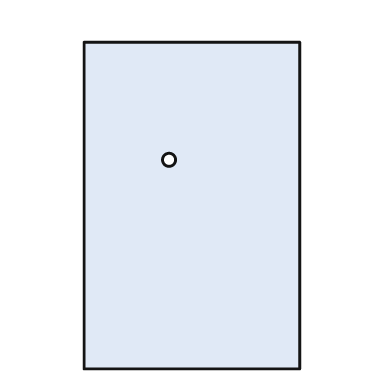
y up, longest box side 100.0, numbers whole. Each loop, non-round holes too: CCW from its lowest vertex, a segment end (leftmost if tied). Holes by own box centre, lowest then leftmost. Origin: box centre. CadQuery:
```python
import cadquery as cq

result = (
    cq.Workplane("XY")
    .moveTo(-33.0, -50.0)
    .lineTo(33.0, -50.0)
    .lineTo(33.0, 50.0)
    .lineTo(-33.0, 50.0)
    .close()
    .moveTo(-7.0, 14.0)
    .circle(2.0)
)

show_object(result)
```